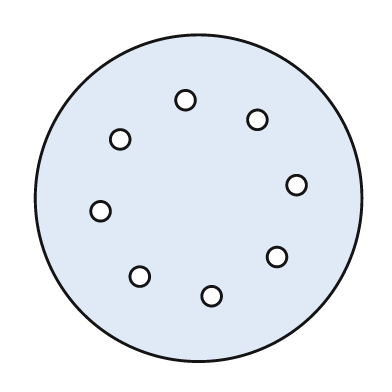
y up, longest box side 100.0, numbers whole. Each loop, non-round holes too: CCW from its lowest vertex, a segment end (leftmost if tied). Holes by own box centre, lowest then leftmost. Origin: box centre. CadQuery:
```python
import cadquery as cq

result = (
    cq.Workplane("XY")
    .moveTo(0.0, 0.0)
    .circle(50.0)
    .moveTo(4.0, -30.0)
    .circle(3.0)
    .moveTo(-18.0, -24.0)
    .circle(3.0)
    .moveTo(24.0, -18.0)
    .circle(3.0)
    .moveTo(-30.0, -4.0)
    .circle(3.0)
    .moveTo(30.0, 4.0)
    .circle(3.0)
    .moveTo(-24.0, 18.0)
    .circle(3.0)
    .moveTo(18.0, 24.0)
    .circle(3.0)
    .moveTo(-4.0, 30.0)
    .circle(3.0)
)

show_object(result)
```